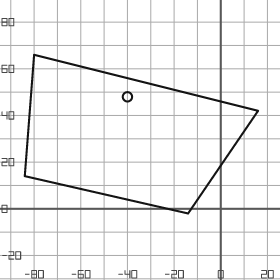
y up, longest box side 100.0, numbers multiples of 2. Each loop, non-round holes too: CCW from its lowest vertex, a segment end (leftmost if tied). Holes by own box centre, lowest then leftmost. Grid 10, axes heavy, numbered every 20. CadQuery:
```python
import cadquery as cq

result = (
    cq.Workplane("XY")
    .moveTo(-14.0, -2.0)
    .lineTo(16.0, 42.0)
    .lineTo(-80.0, 66.0)
    .lineTo(-84.0, 14.0)
    .close()
    .moveTo(-40.0, 48.0)
    .circle(2.0)
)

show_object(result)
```